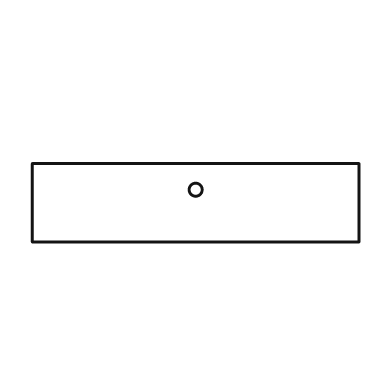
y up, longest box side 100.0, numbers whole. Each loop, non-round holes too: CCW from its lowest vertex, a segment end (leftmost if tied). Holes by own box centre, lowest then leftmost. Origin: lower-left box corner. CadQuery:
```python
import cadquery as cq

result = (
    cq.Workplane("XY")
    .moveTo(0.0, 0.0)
    .lineTo(100.0, 0.0)
    .lineTo(100.0, 24.0)
    .lineTo(0.0, 24.0)
    .close()
    .moveTo(50.0, 16.0)
    .circle(2.0)
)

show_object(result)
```